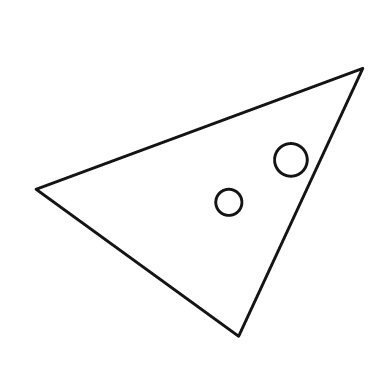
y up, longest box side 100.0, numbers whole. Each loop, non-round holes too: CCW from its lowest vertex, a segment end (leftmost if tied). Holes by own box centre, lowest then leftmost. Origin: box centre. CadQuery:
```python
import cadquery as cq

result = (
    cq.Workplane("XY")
    .moveTo(12.0, -41.0)
    .lineTo(50.0, 41.0)
    .lineTo(-50.0, 4.0)
    .close()
    .moveTo(9.0, 0.0)
    .circle(4.0)
    .moveTo(28.0, 13.0)
    .circle(5.0)
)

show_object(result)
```